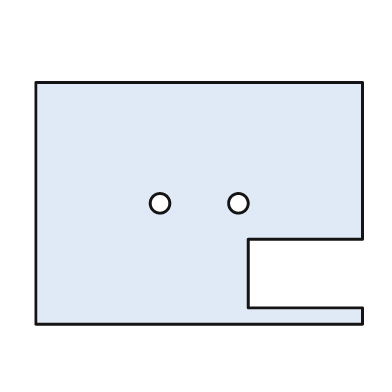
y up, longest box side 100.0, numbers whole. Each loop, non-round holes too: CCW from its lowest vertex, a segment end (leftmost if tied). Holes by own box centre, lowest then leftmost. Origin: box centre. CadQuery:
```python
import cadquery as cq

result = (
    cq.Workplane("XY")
    .moveTo(-50.0, -37.0)
    .lineTo(50.0, -37.0)
    .lineTo(50.0, -32.0)
    .lineTo(15.0, -32.0)
    .lineTo(15.0, -11.0)
    .lineTo(50.0, -11.0)
    .lineTo(50.0, 37.0)
    .lineTo(-50.0, 37.0)
    .close()
    .moveTo(-12.0, 0.0)
    .circle(3.0)
    .moveTo(12.0, 0.0)
    .circle(3.0)
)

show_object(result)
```